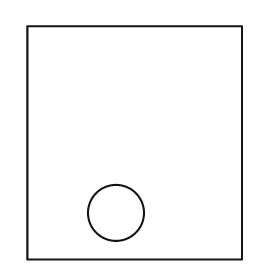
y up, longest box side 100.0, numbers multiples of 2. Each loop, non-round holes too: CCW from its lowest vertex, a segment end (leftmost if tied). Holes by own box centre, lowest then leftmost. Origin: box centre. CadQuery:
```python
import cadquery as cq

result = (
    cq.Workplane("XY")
    .moveTo(-46.0, -50.0)
    .lineTo(46.0, -50.0)
    .lineTo(46.0, 50.0)
    .lineTo(-46.0, 50.0)
    .close()
    .moveTo(-8.0, -30.0)
    .circle(12.0)
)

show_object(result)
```